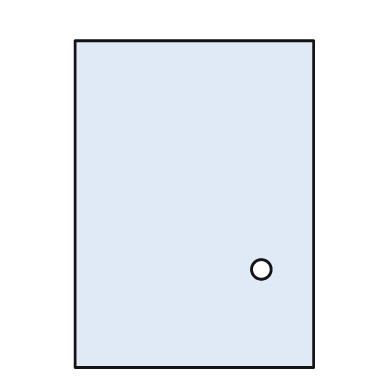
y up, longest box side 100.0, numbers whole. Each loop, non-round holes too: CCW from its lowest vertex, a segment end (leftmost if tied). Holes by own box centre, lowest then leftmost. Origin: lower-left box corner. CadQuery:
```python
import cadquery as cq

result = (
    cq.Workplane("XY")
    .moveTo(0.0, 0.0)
    .lineTo(73.0, 0.0)
    .lineTo(73.0, 100.0)
    .lineTo(0.0, 100.0)
    .close()
    .moveTo(57.0, 30.0)
    .circle(3.0)
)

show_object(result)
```